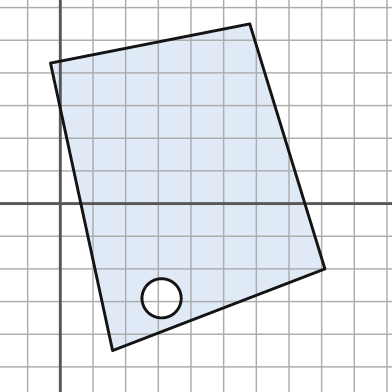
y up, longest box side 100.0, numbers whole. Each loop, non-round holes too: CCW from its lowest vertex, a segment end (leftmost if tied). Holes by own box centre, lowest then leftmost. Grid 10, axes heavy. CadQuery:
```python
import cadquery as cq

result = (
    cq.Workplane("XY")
    .moveTo(16.0, -45.0)
    .lineTo(81.0, -20.0)
    .lineTo(58.0, 55.0)
    .lineTo(-3.0, 43.0)
    .close()
    .moveTo(31.0, -29.0)
    .circle(6.0)
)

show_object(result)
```